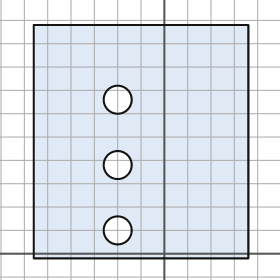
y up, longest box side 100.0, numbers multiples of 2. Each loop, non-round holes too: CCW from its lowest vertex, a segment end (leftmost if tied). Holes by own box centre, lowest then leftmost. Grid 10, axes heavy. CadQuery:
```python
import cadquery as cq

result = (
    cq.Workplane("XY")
    .moveTo(-56.0, -2.0)
    .lineTo(36.0, -2.0)
    .lineTo(36.0, 98.0)
    .lineTo(-56.0, 98.0)
    .close()
    .moveTo(-20.0, 10.0)
    .circle(6.0)
    .moveTo(-20.0, 38.0)
    .circle(6.0)
    .moveTo(-20.0, 66.0)
    .circle(6.0)
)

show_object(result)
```